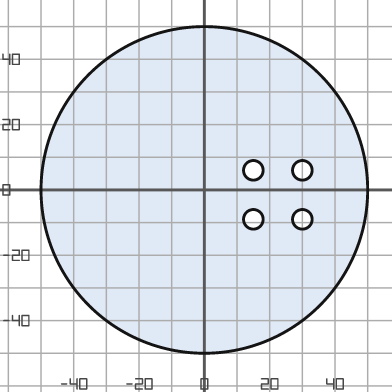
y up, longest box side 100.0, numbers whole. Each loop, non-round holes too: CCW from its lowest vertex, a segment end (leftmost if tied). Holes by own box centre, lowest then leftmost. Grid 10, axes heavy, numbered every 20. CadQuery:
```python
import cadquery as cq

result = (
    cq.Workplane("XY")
    .moveTo(0.0, 0.0)
    .circle(50.0)
    .moveTo(15.0, -9.0)
    .circle(3.0)
    .moveTo(30.0, -9.0)
    .circle(3.0)
    .moveTo(15.0, 6.0)
    .circle(3.0)
    .moveTo(30.0, 6.0)
    .circle(3.0)
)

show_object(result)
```